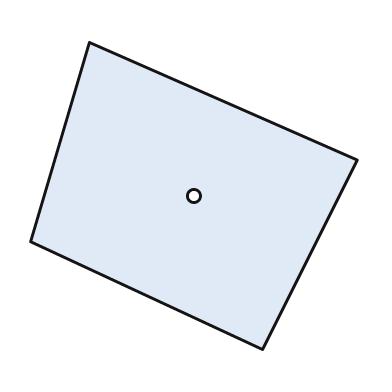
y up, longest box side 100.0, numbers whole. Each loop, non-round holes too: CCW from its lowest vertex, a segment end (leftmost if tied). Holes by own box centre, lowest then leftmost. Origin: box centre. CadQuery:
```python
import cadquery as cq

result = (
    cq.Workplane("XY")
    .moveTo(21.0, -47.0)
    .lineTo(50.0, 11.0)
    .lineTo(-32.0, 47.0)
    .lineTo(-50.0, -14.0)
    .close()
    .moveTo(0.0, 0.0)
    .circle(2.0)
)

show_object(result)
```